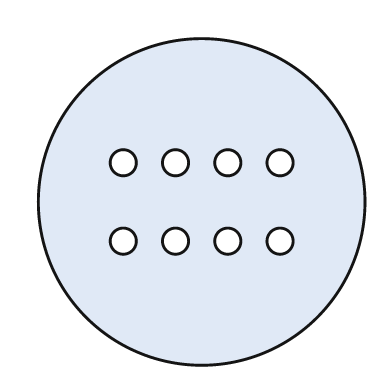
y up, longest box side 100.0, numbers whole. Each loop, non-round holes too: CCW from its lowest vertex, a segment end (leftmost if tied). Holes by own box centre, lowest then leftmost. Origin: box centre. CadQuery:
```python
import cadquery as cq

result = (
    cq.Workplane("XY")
    .moveTo(0.0, 0.0)
    .circle(50.0)
    .moveTo(-24.0, -12.0)
    .circle(4.0)
    .moveTo(-8.0, -12.0)
    .circle(4.0)
    .moveTo(8.0, -12.0)
    .circle(4.0)
    .moveTo(24.0, -12.0)
    .circle(4.0)
    .moveTo(-24.0, 12.0)
    .circle(4.0)
    .moveTo(-8.0, 12.0)
    .circle(4.0)
    .moveTo(8.0, 12.0)
    .circle(4.0)
    .moveTo(24.0, 12.0)
    .circle(4.0)
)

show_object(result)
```